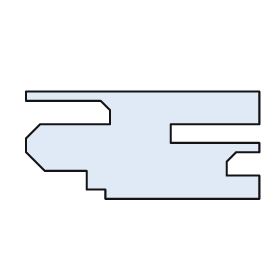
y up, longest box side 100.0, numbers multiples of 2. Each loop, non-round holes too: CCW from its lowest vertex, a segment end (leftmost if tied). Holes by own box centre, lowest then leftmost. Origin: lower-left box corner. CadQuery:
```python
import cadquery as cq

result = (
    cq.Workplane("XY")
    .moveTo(34.0, 0.0)
    .lineTo(100.0, 0.0)
    .lineTo(100.0, 10.0)
    .lineTo(86.0, 10.0)
    .lineTo(86.0, 16.0)
    .lineTo(90.0, 20.0)
    .lineTo(100.0, 20.0)
    .lineTo(100.0, 24.0)
    .lineTo(62.0, 24.0)
    .lineTo(62.0, 32.0)
    .lineTo(100.0, 32.0)
    .lineTo(100.0, 46.0)
    .lineTo(0.0, 46.0)
    .lineTo(0.0, 42.0)
    .lineTo(32.0, 42.0)
    .lineTo(36.0, 38.0)
    .lineTo(36.0, 32.0)
    .lineTo(6.0, 32.0)
    .lineTo(0.0, 26.0)
    .lineTo(0.0, 20.0)
    .lineTo(8.0, 12.0)
    .lineTo(26.0, 12.0)
    .lineTo(26.0, 4.0)
    .lineTo(34.0, 4.0)
    .close()
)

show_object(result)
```